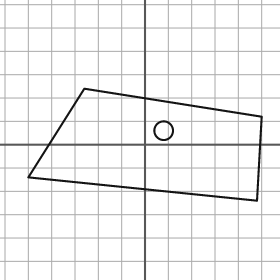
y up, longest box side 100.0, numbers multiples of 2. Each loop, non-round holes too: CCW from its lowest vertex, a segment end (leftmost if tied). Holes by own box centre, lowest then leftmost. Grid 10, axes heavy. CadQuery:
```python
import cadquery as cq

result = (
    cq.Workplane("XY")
    .moveTo(48.0, -24.0)
    .lineTo(50.0, 12.0)
    .lineTo(-26.0, 24.0)
    .lineTo(-50.0, -14.0)
    .close()
    .moveTo(8.0, 6.0)
    .circle(4.0)
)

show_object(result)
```